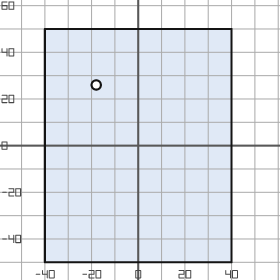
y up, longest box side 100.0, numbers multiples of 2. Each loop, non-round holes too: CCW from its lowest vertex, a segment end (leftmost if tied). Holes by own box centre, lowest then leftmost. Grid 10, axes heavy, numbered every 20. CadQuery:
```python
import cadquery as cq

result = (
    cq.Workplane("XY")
    .moveTo(-40.0, -50.0)
    .lineTo(40.0, -50.0)
    .lineTo(40.0, 50.0)
    .lineTo(-40.0, 50.0)
    .close()
    .moveTo(-18.0, 26.0)
    .circle(2.0)
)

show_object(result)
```